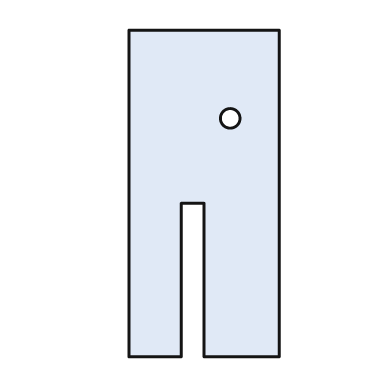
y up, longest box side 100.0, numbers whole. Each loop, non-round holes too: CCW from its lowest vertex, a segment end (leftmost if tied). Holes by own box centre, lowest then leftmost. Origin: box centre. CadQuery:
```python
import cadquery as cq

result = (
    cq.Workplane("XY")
    .moveTo(-23.0, -50.0)
    .lineTo(-7.0, -50.0)
    .lineTo(-7.0, -3.0)
    .lineTo(0.0, -3.0)
    .lineTo(0.0, -50.0)
    .lineTo(23.0, -50.0)
    .lineTo(23.0, 50.0)
    .lineTo(-23.0, 50.0)
    .close()
    .moveTo(8.0, 23.0)
    .circle(3.0)
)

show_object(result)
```